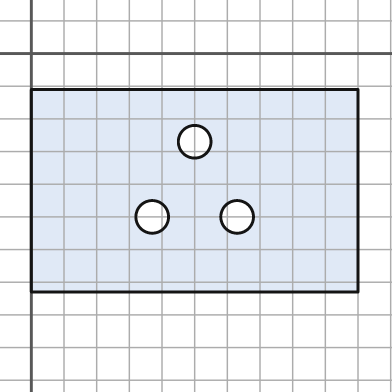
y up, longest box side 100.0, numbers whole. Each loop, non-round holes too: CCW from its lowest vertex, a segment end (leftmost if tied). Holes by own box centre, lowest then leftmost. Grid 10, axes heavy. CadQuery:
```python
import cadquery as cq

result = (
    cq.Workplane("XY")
    .moveTo(0.0, -73.0)
    .lineTo(100.0, -73.0)
    .lineTo(100.0, -11.0)
    .lineTo(0.0, -11.0)
    .close()
    .moveTo(37.0, -50.0)
    .circle(5.0)
    .moveTo(63.0, -50.0)
    .circle(5.0)
    .moveTo(50.0, -27.0)
    .circle(5.0)
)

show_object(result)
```